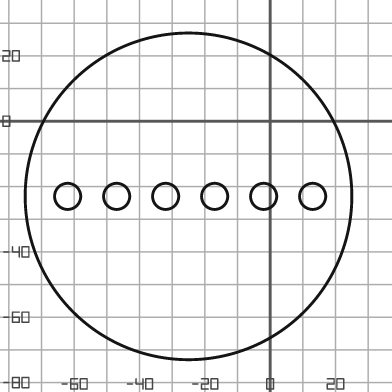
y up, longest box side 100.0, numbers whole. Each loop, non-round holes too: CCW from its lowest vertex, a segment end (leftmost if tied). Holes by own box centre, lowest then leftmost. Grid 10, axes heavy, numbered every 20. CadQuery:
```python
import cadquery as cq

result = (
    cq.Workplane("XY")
    .moveTo(-25.0, -23.0)
    .circle(50.0)
    .moveTo(-62.0, -23.0)
    .circle(4.0)
    .moveTo(-47.0, -23.0)
    .circle(4.0)
    .moveTo(-32.0, -23.0)
    .circle(4.0)
    .moveTo(-17.0, -23.0)
    .circle(4.0)
    .moveTo(-2.0, -23.0)
    .circle(4.0)
    .moveTo(13.0, -23.0)
    .circle(4.0)
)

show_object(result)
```